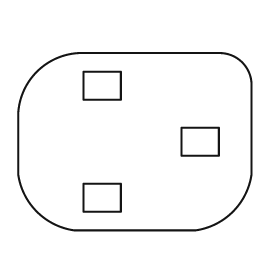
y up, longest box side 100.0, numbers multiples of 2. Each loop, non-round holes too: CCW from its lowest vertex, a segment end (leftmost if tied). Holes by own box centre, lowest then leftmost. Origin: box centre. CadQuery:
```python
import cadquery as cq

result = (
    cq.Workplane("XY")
    .moveTo(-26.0, -38.0)
    .lineTo(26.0, -38.0)
    .threePointArc((42.0, -30.0), (50.0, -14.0))
    .lineTo(50.0, 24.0)
    .threePointArc((46.0, 34.0), (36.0, 38.0))
    .lineTo(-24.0, 38.0)
    .threePointArc((-42.0, 30.0), (-50.0, 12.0))
    .lineTo(-50.0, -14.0)
    .threePointArc((-42.0, -30.0), (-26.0, -38.0))
    .close()
    .moveTo(-22.0, -30.0)
    .lineTo(-6.0, -30.0)
    .lineTo(-6.0, -18.0)
    .lineTo(-22.0, -18.0)
    .close()
    .moveTo(20.0, -6.0)
    .lineTo(36.0, -6.0)
    .lineTo(36.0, 6.0)
    .lineTo(20.0, 6.0)
    .close()
    .moveTo(-22.0, 18.0)
    .lineTo(-6.0, 18.0)
    .lineTo(-6.0, 30.0)
    .lineTo(-22.0, 30.0)
    .close()
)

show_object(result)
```